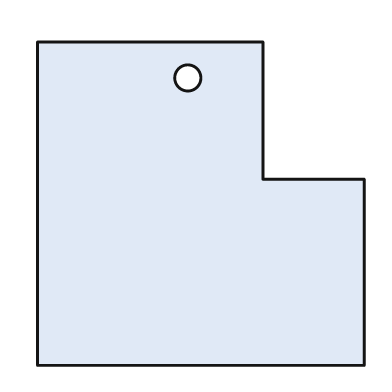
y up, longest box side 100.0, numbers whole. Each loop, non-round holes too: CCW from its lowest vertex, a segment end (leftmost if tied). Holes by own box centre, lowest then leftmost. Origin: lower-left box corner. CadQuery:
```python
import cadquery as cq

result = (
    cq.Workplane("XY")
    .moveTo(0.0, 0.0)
    .lineTo(100.0, 0.0)
    .lineTo(100.0, 57.0)
    .lineTo(69.0, 57.0)
    .lineTo(69.0, 99.0)
    .lineTo(0.0, 99.0)
    .close()
    .moveTo(46.0, 88.0)
    .circle(4.0)
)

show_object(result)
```